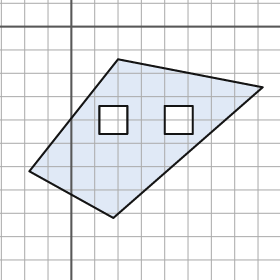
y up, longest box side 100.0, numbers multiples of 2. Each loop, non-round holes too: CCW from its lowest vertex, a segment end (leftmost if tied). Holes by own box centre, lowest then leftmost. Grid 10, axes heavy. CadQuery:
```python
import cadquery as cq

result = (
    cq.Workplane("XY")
    .moveTo(18.0, -82.0)
    .lineTo(82.0, -26.0)
    .lineTo(20.0, -14.0)
    .lineTo(-18.0, -62.0)
    .close()
    .moveTo(12.0, -46.0)
    .lineTo(24.0, -46.0)
    .lineTo(24.0, -34.0)
    .lineTo(12.0, -34.0)
    .close()
    .moveTo(40.0, -46.0)
    .lineTo(52.0, -46.0)
    .lineTo(52.0, -34.0)
    .lineTo(40.0, -34.0)
    .close()
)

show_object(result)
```